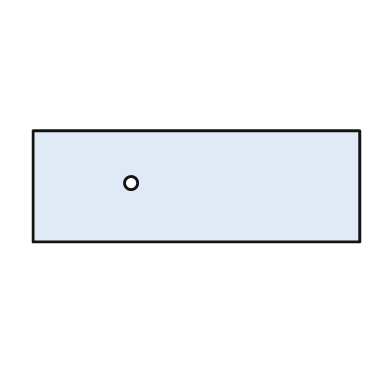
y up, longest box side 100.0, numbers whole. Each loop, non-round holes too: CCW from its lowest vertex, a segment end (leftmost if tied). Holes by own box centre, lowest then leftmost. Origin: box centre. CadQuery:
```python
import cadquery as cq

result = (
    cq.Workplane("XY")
    .moveTo(-50.0, -17.0)
    .lineTo(50.0, -17.0)
    .lineTo(50.0, 17.0)
    .lineTo(-50.0, 17.0)
    .close()
    .moveTo(-20.0, 1.0)
    .circle(2.0)
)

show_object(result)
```